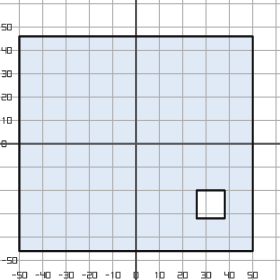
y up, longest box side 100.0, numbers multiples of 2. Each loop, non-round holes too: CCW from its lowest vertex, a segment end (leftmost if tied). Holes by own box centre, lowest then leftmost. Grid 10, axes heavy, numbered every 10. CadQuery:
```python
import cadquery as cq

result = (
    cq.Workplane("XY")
    .moveTo(-50.0, -46.0)
    .lineTo(50.0, -46.0)
    .lineTo(50.0, 46.0)
    .lineTo(-50.0, 46.0)
    .close()
    .moveTo(26.0, -32.0)
    .lineTo(38.0, -32.0)
    .lineTo(38.0, -20.0)
    .lineTo(26.0, -20.0)
    .close()
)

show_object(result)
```